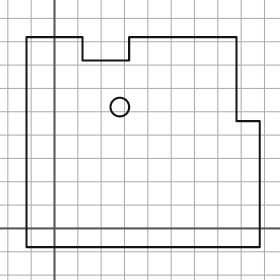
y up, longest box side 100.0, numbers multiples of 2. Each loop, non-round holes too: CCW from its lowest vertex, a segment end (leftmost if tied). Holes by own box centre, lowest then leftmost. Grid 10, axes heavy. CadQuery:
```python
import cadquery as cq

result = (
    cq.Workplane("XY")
    .moveTo(-12.0, -8.0)
    .lineTo(88.0, -8.0)
    .lineTo(88.0, 46.0)
    .lineTo(78.0, 46.0)
    .lineTo(78.0, 82.0)
    .lineTo(32.0, 82.0)
    .lineTo(32.0, 72.0)
    .lineTo(12.0, 72.0)
    .lineTo(12.0, 82.0)
    .lineTo(-12.0, 82.0)
    .close()
    .moveTo(28.0, 52.0)
    .circle(4.0)
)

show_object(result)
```